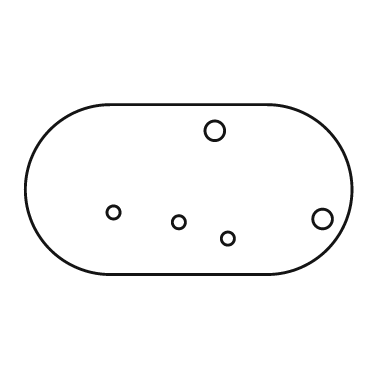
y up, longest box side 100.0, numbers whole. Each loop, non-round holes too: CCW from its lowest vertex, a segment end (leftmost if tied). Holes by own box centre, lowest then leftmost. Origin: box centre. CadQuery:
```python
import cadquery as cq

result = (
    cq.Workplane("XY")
    .moveTo(-24.0, -26.0)
    .lineTo(24.0, -26.0)
    .threePointArc((50.0, 0.0), (24.0, 26.0))
    .lineTo(-24.0, 26.0)
    .threePointArc((-50.0, 0.0), (-24.0, -26.0))
    .close()
    .moveTo(12.0, -15.0)
    .circle(2.0)
    .moveTo(-3.0, -10.0)
    .circle(2.0)
    .moveTo(41.0, -9.0)
    .circle(3.0)
    .moveTo(-23.0, -7.0)
    .circle(2.0)
    .moveTo(8.0, 18.0)
    .circle(3.0)
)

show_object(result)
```